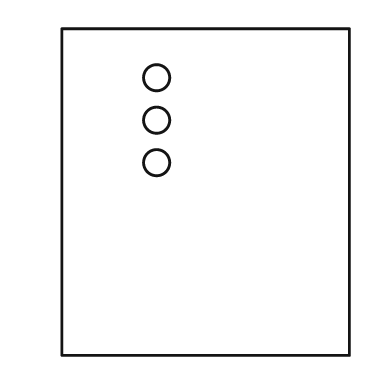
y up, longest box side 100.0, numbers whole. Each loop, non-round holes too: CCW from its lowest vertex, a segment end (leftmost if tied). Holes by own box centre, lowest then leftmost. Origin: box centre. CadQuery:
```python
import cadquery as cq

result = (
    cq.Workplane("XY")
    .moveTo(-44.0, -50.0)
    .lineTo(44.0, -50.0)
    .lineTo(44.0, 50.0)
    .lineTo(-44.0, 50.0)
    .close()
    .moveTo(-15.0, 9.0)
    .circle(4.0)
    .moveTo(-15.0, 22.0)
    .circle(4.0)
    .moveTo(-15.0, 35.0)
    .circle(4.0)
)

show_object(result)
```